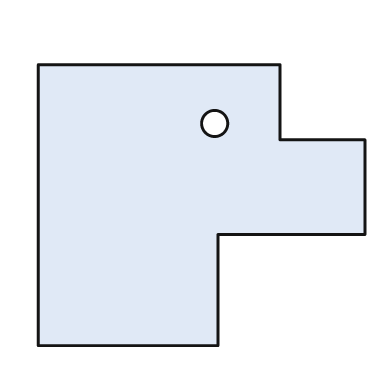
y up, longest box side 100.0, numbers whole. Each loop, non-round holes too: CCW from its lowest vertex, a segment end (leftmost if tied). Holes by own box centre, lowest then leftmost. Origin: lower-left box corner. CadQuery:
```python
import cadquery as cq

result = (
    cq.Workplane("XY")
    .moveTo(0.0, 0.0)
    .lineTo(55.0, 0.0)
    .lineTo(55.0, 34.0)
    .lineTo(100.0, 34.0)
    .lineTo(100.0, 63.0)
    .lineTo(74.0, 63.0)
    .lineTo(74.0, 86.0)
    .lineTo(0.0, 86.0)
    .close()
    .moveTo(54.0, 68.0)
    .circle(4.0)
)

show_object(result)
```